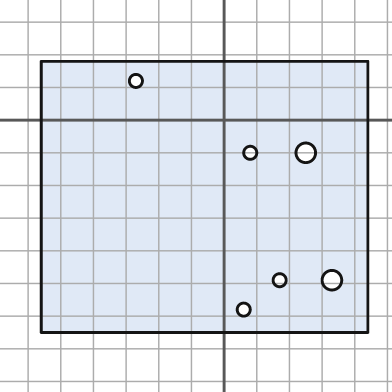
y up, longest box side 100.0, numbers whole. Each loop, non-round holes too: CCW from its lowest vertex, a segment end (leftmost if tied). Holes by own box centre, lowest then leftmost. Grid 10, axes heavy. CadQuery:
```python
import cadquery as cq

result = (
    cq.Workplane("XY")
    .moveTo(-56.0, -65.0)
    .lineTo(44.0, -65.0)
    .lineTo(44.0, 18.0)
    .lineTo(-56.0, 18.0)
    .close()
    .moveTo(6.0, -58.0)
    .circle(2.0)
    .moveTo(17.0, -49.0)
    .circle(2.0)
    .moveTo(33.0, -49.0)
    .circle(3.0)
    .moveTo(8.0, -10.0)
    .circle(2.0)
    .moveTo(25.0, -10.0)
    .circle(3.0)
    .moveTo(-27.0, 12.0)
    .circle(2.0)
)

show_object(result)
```